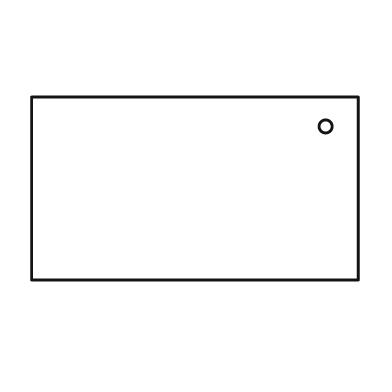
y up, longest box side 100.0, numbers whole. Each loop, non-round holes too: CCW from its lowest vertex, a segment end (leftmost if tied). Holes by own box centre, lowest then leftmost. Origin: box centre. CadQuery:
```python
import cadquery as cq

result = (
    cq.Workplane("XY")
    .moveTo(-50.0, -28.0)
    .lineTo(50.0, -28.0)
    .lineTo(50.0, 28.0)
    .lineTo(-50.0, 28.0)
    .close()
    .moveTo(40.0, 19.0)
    .circle(2.0)
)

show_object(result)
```